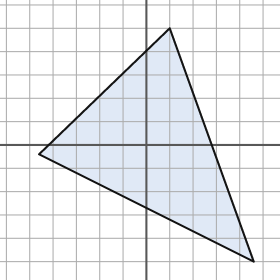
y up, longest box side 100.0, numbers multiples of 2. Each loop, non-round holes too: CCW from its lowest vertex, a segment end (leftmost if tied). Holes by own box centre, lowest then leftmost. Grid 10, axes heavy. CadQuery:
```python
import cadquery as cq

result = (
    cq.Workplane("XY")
    .moveTo(46.0, -50.0)
    .lineTo(10.0, 50.0)
    .lineTo(-46.0, -4.0)
    .close()
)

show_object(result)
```